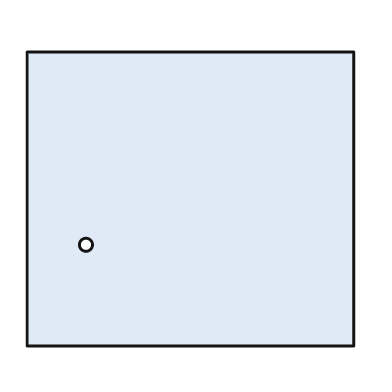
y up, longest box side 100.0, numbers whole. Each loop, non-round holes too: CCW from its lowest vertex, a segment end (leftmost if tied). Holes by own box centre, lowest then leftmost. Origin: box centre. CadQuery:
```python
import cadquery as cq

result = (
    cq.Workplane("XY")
    .moveTo(-50.0, -45.0)
    .lineTo(50.0, -45.0)
    .lineTo(50.0, 45.0)
    .lineTo(-50.0, 45.0)
    .close()
    .moveTo(-32.0, -14.0)
    .circle(2.0)
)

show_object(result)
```